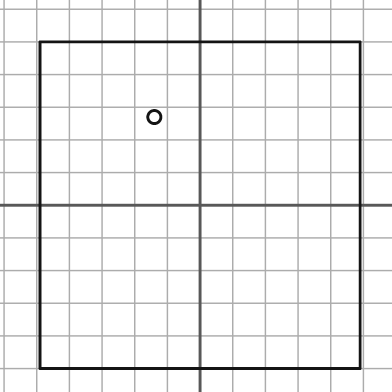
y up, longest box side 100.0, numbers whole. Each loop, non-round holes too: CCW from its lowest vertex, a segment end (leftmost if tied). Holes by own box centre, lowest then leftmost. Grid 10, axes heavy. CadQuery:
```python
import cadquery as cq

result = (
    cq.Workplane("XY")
    .moveTo(-49.0, -50.0)
    .lineTo(49.0, -50.0)
    .lineTo(49.0, 50.0)
    .lineTo(-49.0, 50.0)
    .close()
    .moveTo(-14.0, 27.0)
    .circle(2.0)
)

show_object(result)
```